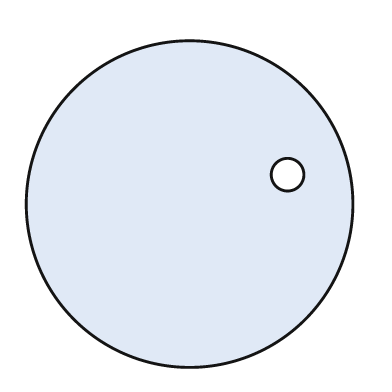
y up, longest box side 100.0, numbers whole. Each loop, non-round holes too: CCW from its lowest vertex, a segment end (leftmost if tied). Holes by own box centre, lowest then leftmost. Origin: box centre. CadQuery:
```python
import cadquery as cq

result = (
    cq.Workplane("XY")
    .moveTo(0.0, 0.0)
    .circle(50.0)
    .moveTo(30.0, 9.0)
    .circle(5.0)
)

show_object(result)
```